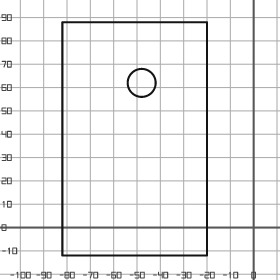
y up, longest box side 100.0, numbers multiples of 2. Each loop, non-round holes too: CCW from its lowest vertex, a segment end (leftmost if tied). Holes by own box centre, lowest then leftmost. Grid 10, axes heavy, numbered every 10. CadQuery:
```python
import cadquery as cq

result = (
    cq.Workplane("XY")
    .moveTo(-82.0, -12.0)
    .lineTo(-20.0, -12.0)
    .lineTo(-20.0, 88.0)
    .lineTo(-82.0, 88.0)
    .close()
    .moveTo(-48.0, 62.0)
    .circle(6.0)
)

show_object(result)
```